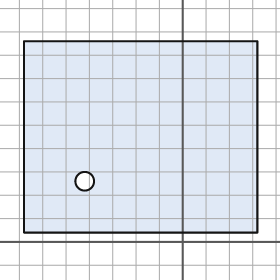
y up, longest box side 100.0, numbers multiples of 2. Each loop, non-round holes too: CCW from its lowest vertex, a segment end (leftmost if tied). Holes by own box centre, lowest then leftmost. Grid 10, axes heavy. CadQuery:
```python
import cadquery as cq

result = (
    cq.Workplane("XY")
    .moveTo(-68.0, 4.0)
    .lineTo(32.0, 4.0)
    .lineTo(32.0, 86.0)
    .lineTo(-68.0, 86.0)
    .close()
    .moveTo(-42.0, 26.0)
    .circle(4.0)
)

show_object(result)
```